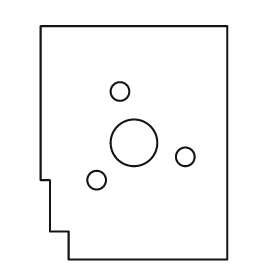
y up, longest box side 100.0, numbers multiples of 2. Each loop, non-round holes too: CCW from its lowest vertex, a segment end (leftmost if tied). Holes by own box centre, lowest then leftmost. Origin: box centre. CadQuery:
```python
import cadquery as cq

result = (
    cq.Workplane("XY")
    .moveTo(-28.0, -50.0)
    .lineTo(40.0, -50.0)
    .lineTo(40.0, 50.0)
    .lineTo(-40.0, 50.0)
    .lineTo(-40.0, -16.0)
    .lineTo(-36.0, -16.0)
    .lineTo(-36.0, -38.0)
    .lineTo(-28.0, -38.0)
    .close()
    .moveTo(-16.0, -16.0)
    .circle(4.0)
    .moveTo(22.0, -6.0)
    .circle(4.0)
    .moveTo(0.0, 0.0)
    .circle(10.0)
    .moveTo(-6.0, 22.0)
    .circle(4.0)
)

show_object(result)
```